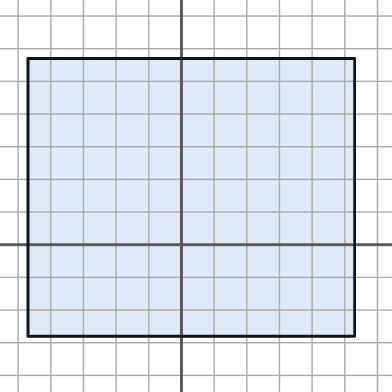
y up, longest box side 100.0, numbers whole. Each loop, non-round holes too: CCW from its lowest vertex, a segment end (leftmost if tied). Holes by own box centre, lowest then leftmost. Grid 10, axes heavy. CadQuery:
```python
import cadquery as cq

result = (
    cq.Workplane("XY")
    .moveTo(-47.0, -28.0)
    .lineTo(53.0, -28.0)
    .lineTo(53.0, 57.0)
    .lineTo(-47.0, 57.0)
    .close()
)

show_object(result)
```